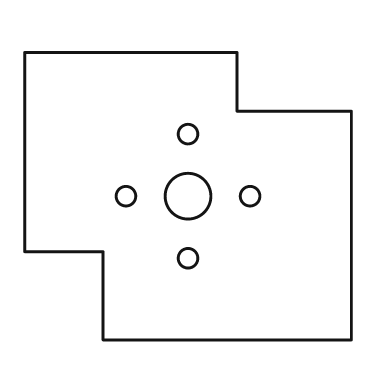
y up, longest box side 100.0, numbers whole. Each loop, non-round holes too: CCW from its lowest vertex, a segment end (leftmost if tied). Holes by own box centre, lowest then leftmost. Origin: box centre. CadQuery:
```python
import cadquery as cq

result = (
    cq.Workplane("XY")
    .moveTo(-26.0, -44.0)
    .lineTo(50.0, -44.0)
    .lineTo(50.0, 26.0)
    .lineTo(15.0, 26.0)
    .lineTo(15.0, 44.0)
    .lineTo(-50.0, 44.0)
    .lineTo(-50.0, -17.0)
    .lineTo(-26.0, -17.0)
    .close()
    .moveTo(0.0, -19.0)
    .circle(3.0)
    .moveTo(-19.0, 0.0)
    .circle(3.0)
    .moveTo(0.0, 0.0)
    .circle(7.0)
    .moveTo(19.0, 0.0)
    .circle(3.0)
    .moveTo(0.0, 19.0)
    .circle(3.0)
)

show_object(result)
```